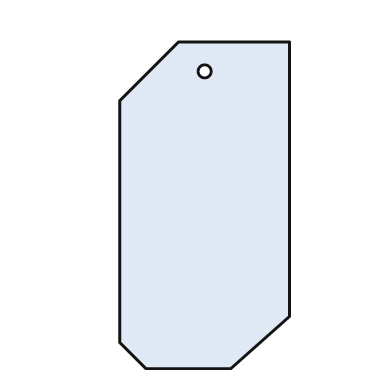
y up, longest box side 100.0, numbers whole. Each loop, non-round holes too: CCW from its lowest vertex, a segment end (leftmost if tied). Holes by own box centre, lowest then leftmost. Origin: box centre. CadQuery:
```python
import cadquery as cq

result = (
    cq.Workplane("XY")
    .moveTo(-18.0, -50.0)
    .lineTo(8.0, -50.0)
    .lineTo(26.0, -34.0)
    .lineTo(26.0, 50.0)
    .lineTo(-8.0, 50.0)
    .lineTo(-26.0, 32.0)
    .lineTo(-26.0, -42.0)
    .close()
    .moveTo(0.0, 41.0)
    .circle(2.0)
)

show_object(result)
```